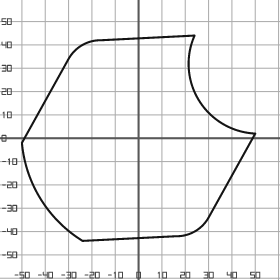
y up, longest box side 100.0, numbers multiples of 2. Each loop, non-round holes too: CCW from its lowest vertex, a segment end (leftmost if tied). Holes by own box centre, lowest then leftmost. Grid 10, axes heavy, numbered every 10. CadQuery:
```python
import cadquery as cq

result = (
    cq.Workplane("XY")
    .moveTo(-24.0, -44.0)
    .lineTo(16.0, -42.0)
    .threePointArc((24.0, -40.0), (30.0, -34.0))
    .lineTo(50.0, 2.0)
    .threePointArc((26.0, 16.0), (24.0, 44.0))
    .lineTo(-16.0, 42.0)
    .threePointArc((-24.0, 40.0), (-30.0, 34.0))
    .lineTo(-50.0, -2.0)
    .threePointArc((-42.0, -26.0), (-24.0, -44.0))
    .close()
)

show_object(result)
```